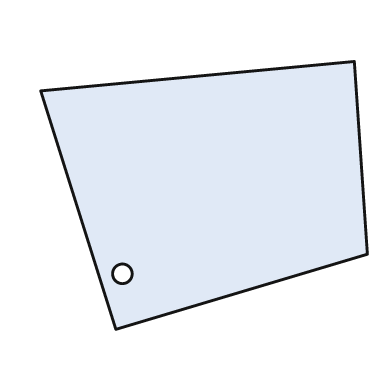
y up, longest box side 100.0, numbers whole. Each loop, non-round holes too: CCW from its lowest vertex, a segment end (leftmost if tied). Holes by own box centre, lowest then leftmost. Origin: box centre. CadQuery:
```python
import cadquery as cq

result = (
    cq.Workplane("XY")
    .moveTo(-27.0, -41.0)
    .lineTo(50.0, -18.0)
    .lineTo(46.0, 41.0)
    .lineTo(-50.0, 32.0)
    .close()
    .moveTo(-25.0, -24.0)
    .circle(3.0)
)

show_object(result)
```